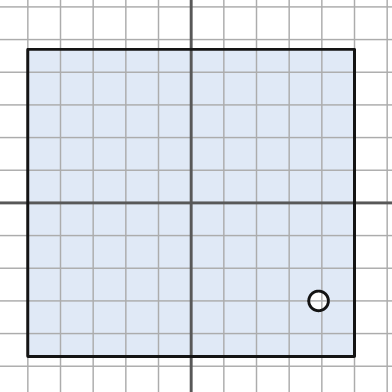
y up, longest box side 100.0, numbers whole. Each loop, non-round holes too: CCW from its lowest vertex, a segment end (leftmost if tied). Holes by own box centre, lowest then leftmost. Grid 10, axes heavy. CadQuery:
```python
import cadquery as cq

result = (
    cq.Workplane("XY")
    .moveTo(-50.0, -47.0)
    .lineTo(50.0, -47.0)
    .lineTo(50.0, 47.0)
    .lineTo(-50.0, 47.0)
    .close()
    .moveTo(39.0, -30.0)
    .circle(3.0)
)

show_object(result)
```